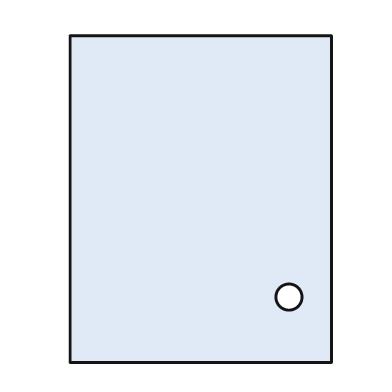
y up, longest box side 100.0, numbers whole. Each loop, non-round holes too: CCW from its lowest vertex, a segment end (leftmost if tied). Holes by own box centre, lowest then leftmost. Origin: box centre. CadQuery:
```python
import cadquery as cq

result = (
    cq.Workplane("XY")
    .moveTo(-40.0, -50.0)
    .lineTo(40.0, -50.0)
    .lineTo(40.0, 50.0)
    .lineTo(-40.0, 50.0)
    .close()
    .moveTo(27.0, -30.0)
    .circle(4.0)
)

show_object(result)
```